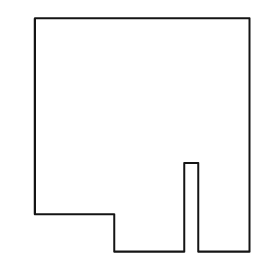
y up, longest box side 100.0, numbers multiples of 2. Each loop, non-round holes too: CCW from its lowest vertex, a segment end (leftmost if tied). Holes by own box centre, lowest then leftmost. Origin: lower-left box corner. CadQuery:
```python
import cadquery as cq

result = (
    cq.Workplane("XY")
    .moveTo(34.0, 0.0)
    .lineTo(64.0, 0.0)
    .lineTo(64.0, 38.0)
    .lineTo(70.0, 38.0)
    .lineTo(70.0, 0.0)
    .lineTo(92.0, 0.0)
    .lineTo(92.0, 100.0)
    .lineTo(0.0, 100.0)
    .lineTo(0.0, 16.0)
    .lineTo(34.0, 16.0)
    .close()
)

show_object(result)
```